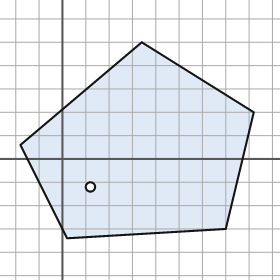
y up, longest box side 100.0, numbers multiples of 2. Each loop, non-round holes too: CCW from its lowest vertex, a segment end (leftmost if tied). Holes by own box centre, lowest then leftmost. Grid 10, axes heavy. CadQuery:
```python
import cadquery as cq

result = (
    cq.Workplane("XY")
    .moveTo(2.0, -34.0)
    .lineTo(70.0, -30.0)
    .lineTo(82.0, 20.0)
    .lineTo(34.0, 50.0)
    .lineTo(-18.0, 6.0)
    .close()
    .moveTo(12.0, -12.0)
    .circle(2.0)
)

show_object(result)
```